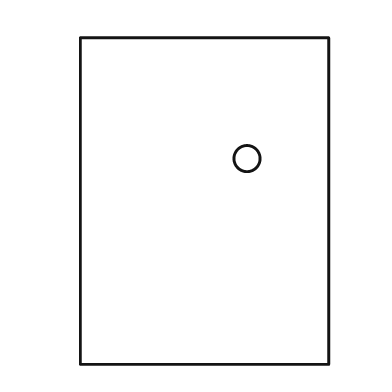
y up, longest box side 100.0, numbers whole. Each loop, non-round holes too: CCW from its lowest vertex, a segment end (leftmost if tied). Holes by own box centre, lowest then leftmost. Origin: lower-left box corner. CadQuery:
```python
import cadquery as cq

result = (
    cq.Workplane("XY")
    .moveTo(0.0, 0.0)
    .lineTo(76.0, 0.0)
    .lineTo(76.0, 100.0)
    .lineTo(0.0, 100.0)
    .close()
    .moveTo(51.0, 63.0)
    .circle(4.0)
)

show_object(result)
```